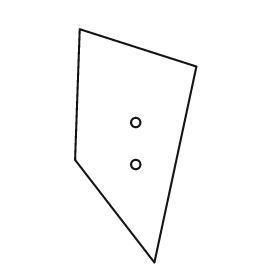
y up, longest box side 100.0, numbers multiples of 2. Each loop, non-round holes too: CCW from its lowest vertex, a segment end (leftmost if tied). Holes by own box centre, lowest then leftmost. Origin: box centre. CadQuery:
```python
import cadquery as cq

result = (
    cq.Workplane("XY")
    .moveTo(8.0, -50.0)
    .lineTo(26.0, 34.0)
    .lineTo(-24.0, 50.0)
    .lineTo(-26.0, -6.0)
    .close()
    .moveTo(0.0, -8.0)
    .circle(2.0)
    .moveTo(0.0, 10.0)
    .circle(2.0)
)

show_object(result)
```